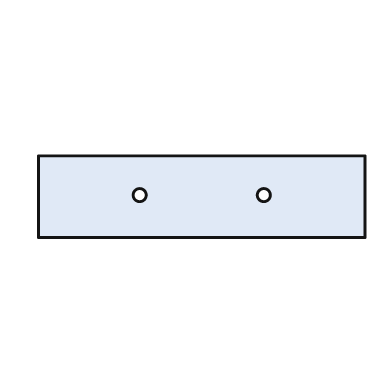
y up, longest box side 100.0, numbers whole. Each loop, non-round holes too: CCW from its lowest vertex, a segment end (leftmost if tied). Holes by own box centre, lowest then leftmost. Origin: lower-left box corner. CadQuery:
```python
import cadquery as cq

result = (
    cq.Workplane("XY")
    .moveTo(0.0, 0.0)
    .lineTo(100.0, 0.0)
    .lineTo(100.0, 25.0)
    .lineTo(0.0, 25.0)
    .close()
    .moveTo(31.0, 13.0)
    .circle(2.0)
    .moveTo(69.0, 13.0)
    .circle(2.0)
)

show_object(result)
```